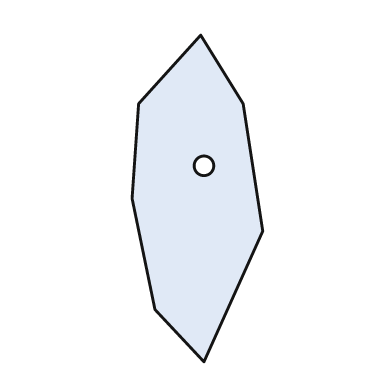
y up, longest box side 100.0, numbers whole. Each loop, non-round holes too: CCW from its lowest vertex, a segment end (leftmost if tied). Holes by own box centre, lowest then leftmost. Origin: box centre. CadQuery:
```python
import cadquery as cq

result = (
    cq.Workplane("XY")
    .moveTo(2.0, -50.0)
    .lineTo(20.0, -10.0)
    .lineTo(14.0, 29.0)
    .lineTo(1.0, 50.0)
    .lineTo(-18.0, 29.0)
    .lineTo(-20.0, 0.0)
    .lineTo(-13.0, -34.0)
    .close()
    .moveTo(2.0, 10.0)
    .circle(3.0)
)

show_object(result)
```